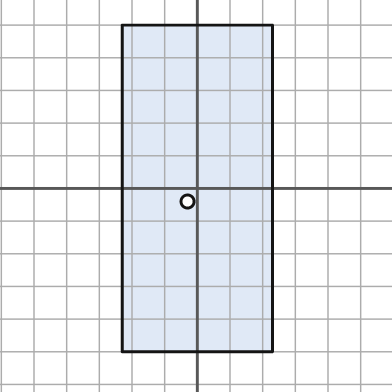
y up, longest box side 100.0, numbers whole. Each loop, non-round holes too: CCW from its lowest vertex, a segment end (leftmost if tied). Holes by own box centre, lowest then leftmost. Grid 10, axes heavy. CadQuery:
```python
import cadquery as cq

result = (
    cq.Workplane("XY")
    .moveTo(-23.0, -50.0)
    .lineTo(23.0, -50.0)
    .lineTo(23.0, 50.0)
    .lineTo(-23.0, 50.0)
    .close()
    .moveTo(-3.0, -4.0)
    .circle(2.0)
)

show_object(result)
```